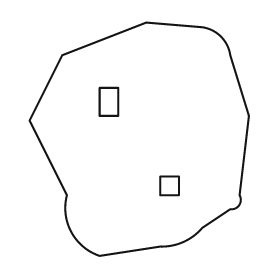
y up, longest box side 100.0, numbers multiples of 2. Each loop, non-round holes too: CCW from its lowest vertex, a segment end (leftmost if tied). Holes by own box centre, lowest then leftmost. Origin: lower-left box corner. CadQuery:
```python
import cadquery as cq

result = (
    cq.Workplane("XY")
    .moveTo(30.0, 0.0)
    .lineTo(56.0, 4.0)
    .threePointArc((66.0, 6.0), (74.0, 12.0))
    .lineTo(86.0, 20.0)
    .threePointArc((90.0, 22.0), (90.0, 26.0))
    .lineTo(94.0, 60.0)
    .lineTo(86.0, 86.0)
    .threePointArc((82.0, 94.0), (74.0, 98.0))
    .lineTo(50.0, 100.0)
    .lineTo(14.0, 86.0)
    .lineTo(0.0, 58.0)
    .lineTo(16.0, 26.0)
    .threePointArc((18.0, 10.0), (30.0, 0.0))
    .close()
    .moveTo(56.0, 26.0)
    .lineTo(64.0, 26.0)
    .lineTo(64.0, 34.0)
    .lineTo(56.0, 34.0)
    .close()
    .moveTo(30.0, 60.0)
    .lineTo(38.0, 60.0)
    .lineTo(38.0, 72.0)
    .lineTo(30.0, 72.0)
    .close()
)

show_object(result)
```